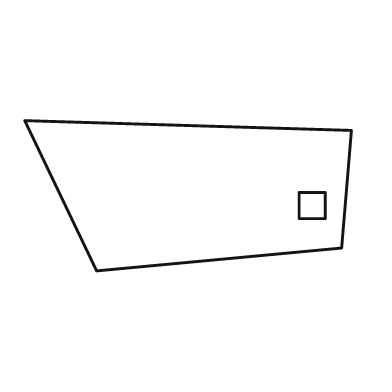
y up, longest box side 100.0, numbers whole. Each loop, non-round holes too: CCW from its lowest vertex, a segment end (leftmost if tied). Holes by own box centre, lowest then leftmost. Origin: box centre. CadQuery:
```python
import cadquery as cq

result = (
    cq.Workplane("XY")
    .moveTo(-28.0, -23.0)
    .lineTo(47.0, -16.0)
    .lineTo(50.0, 20.0)
    .lineTo(-50.0, 23.0)
    .close()
    .moveTo(34.0, -7.0)
    .lineTo(42.0, -7.0)
    .lineTo(42.0, 1.0)
    .lineTo(34.0, 1.0)
    .close()
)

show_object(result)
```